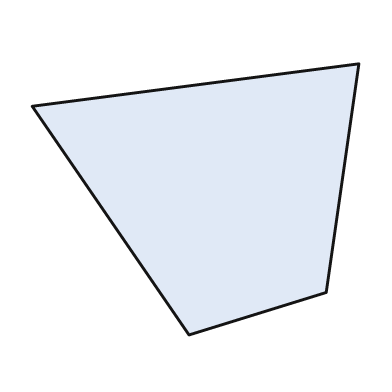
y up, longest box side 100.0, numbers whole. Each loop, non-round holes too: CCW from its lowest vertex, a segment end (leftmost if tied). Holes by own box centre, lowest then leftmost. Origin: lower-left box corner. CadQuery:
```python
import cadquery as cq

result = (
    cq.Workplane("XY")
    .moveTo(48.0, 0.0)
    .lineTo(90.0, 13.0)
    .lineTo(100.0, 83.0)
    .lineTo(0.0, 70.0)
    .close()
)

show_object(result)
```